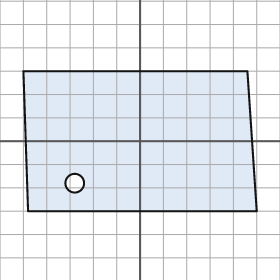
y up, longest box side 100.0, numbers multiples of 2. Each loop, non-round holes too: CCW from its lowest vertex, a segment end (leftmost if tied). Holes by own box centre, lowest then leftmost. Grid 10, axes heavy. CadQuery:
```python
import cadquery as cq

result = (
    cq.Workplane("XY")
    .moveTo(-48.0, -30.0)
    .lineTo(50.0, -30.0)
    .lineTo(46.0, 30.0)
    .lineTo(-50.0, 30.0)
    .close()
    .moveTo(-28.0, -18.0)
    .circle(4.0)
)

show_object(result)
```